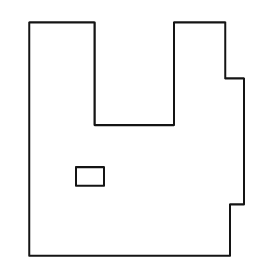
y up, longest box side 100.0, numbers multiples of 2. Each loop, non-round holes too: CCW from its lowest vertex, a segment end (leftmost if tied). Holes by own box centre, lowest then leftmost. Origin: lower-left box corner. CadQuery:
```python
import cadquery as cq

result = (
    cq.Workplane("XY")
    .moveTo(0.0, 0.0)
    .lineTo(86.0, 0.0)
    .lineTo(86.0, 22.0)
    .lineTo(92.0, 22.0)
    .lineTo(92.0, 76.0)
    .lineTo(84.0, 76.0)
    .lineTo(84.0, 100.0)
    .lineTo(62.0, 100.0)
    .lineTo(62.0, 56.0)
    .lineTo(28.0, 56.0)
    .lineTo(28.0, 100.0)
    .lineTo(0.0, 100.0)
    .close()
    .moveTo(20.0, 30.0)
    .lineTo(32.0, 30.0)
    .lineTo(32.0, 38.0)
    .lineTo(20.0, 38.0)
    .close()
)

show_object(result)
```